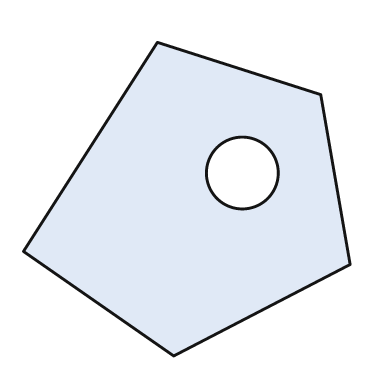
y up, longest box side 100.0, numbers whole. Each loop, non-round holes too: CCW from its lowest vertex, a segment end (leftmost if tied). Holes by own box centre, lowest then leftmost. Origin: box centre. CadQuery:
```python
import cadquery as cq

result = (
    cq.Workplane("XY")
    .moveTo(-4.0, -48.0)
    .lineTo(50.0, -20.0)
    .lineTo(41.0, 32.0)
    .lineTo(-9.0, 48.0)
    .lineTo(-50.0, -16.0)
    .close()
    .moveTo(17.0, 8.0)
    .circle(11.0)
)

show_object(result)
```